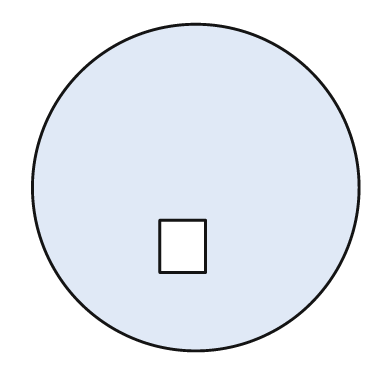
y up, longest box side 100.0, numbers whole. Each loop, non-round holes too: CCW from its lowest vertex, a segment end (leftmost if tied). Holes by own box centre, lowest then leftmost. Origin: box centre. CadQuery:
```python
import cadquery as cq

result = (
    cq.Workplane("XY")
    .moveTo(0.0, 0.0)
    .circle(50.0)
    .moveTo(-11.0, -26.0)
    .lineTo(3.0, -26.0)
    .lineTo(3.0, -10.0)
    .lineTo(-11.0, -10.0)
    .close()
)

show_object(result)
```